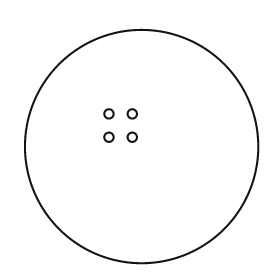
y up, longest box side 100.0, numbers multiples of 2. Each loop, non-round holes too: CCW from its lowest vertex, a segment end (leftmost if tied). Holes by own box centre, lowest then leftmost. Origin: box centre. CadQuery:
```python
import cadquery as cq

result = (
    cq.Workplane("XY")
    .moveTo(0.0, 0.0)
    .circle(50.0)
    .moveTo(-14.0, 4.0)
    .circle(2.0)
    .moveTo(-4.0, 4.0)
    .circle(2.0)
    .moveTo(-14.0, 14.0)
    .circle(2.0)
    .moveTo(-4.0, 14.0)
    .circle(2.0)
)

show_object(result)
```